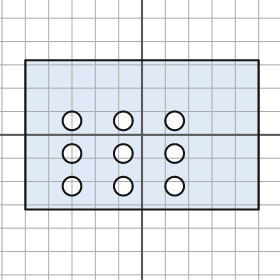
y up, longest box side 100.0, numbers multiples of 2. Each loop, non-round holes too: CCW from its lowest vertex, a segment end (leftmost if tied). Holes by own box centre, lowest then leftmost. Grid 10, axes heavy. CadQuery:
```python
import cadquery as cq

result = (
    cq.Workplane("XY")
    .moveTo(-50.0, -32.0)
    .lineTo(50.0, -32.0)
    .lineTo(50.0, 32.0)
    .lineTo(-50.0, 32.0)
    .close()
    .moveTo(-30.0, -22.0)
    .circle(4.0)
    .moveTo(-8.0, -22.0)
    .circle(4.0)
    .moveTo(14.0, -22.0)
    .circle(4.0)
    .moveTo(-30.0, -8.0)
    .circle(4.0)
    .moveTo(-8.0, -8.0)
    .circle(4.0)
    .moveTo(14.0, -8.0)
    .circle(4.0)
    .moveTo(-30.0, 6.0)
    .circle(4.0)
    .moveTo(-8.0, 6.0)
    .circle(4.0)
    .moveTo(14.0, 6.0)
    .circle(4.0)
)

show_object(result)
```